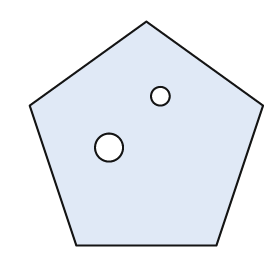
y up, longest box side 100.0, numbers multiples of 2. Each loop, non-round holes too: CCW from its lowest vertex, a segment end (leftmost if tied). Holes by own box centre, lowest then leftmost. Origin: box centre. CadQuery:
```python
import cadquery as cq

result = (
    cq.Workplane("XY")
    .moveTo(-30.0, -48.0)
    .lineTo(30.0, -48.0)
    .lineTo(50.0, 12.0)
    .lineTo(0.0, 48.0)
    .lineTo(-50.0, 12.0)
    .close()
    .moveTo(-16.0, -6.0)
    .circle(6.0)
    .moveTo(6.0, 16.0)
    .circle(4.0)
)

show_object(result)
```